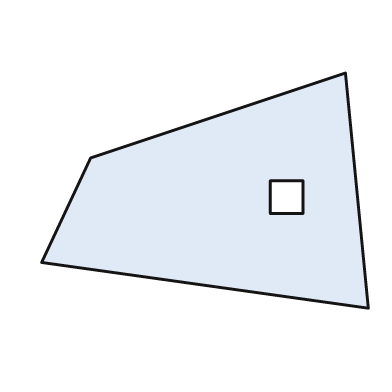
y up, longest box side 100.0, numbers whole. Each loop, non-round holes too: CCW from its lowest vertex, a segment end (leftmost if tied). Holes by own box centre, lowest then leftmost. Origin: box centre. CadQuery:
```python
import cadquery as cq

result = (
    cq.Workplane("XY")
    .moveTo(50.0, -36.0)
    .lineTo(43.0, 36.0)
    .lineTo(-35.0, 10.0)
    .lineTo(-50.0, -22.0)
    .close()
    .moveTo(20.0, -7.0)
    .lineTo(30.0, -7.0)
    .lineTo(30.0, 3.0)
    .lineTo(20.0, 3.0)
    .close()
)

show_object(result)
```